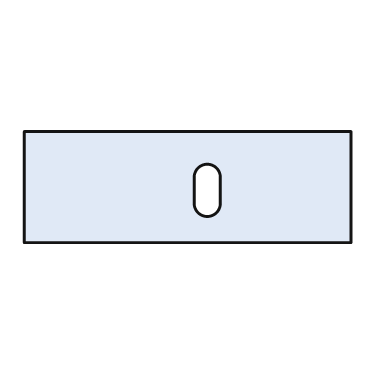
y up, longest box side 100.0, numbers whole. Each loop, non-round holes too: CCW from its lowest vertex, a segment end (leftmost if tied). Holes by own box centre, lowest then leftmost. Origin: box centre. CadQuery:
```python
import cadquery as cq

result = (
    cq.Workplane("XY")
    .moveTo(-50.0, -17.0)
    .lineTo(50.0, -17.0)
    .lineTo(50.0, 17.0)
    .lineTo(-50.0, 17.0)
    .close()
    .moveTo(2.0, -5.0)
    .threePointArc((6.0, -9.0), (10.0, -5.0))
    .lineTo(10.0, 3.0)
    .threePointArc((6.0, 7.0), (2.0, 3.0))
    .close()
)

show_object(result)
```